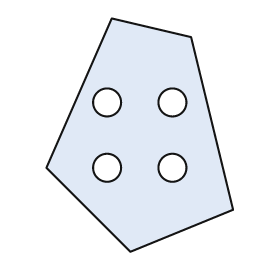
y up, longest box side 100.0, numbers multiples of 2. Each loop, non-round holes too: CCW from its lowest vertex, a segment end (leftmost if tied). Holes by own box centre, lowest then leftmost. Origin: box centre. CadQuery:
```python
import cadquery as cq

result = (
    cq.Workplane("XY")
    .moveTo(-4.0, -50.0)
    .lineTo(40.0, -32.0)
    .lineTo(22.0, 42.0)
    .lineTo(-12.0, 50.0)
    .lineTo(-40.0, -14.0)
    .close()
    .moveTo(-14.0, -14.0)
    .circle(6.0)
    .moveTo(14.0, -14.0)
    .circle(6.0)
    .moveTo(-14.0, 14.0)
    .circle(6.0)
    .moveTo(14.0, 14.0)
    .circle(6.0)
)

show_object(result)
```